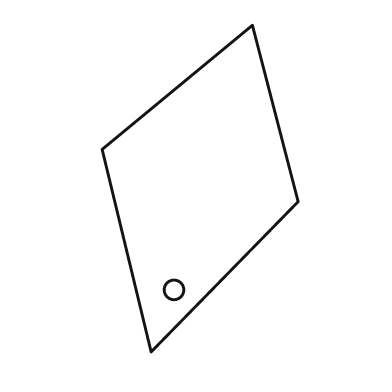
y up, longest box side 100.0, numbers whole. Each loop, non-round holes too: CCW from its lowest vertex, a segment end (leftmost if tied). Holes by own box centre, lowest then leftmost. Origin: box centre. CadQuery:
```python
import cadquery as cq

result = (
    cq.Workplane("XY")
    .moveTo(-15.0, -50.0)
    .lineTo(30.0, -4.0)
    .lineTo(16.0, 50.0)
    .lineTo(-30.0, 12.0)
    .close()
    .moveTo(-8.0, -31.0)
    .circle(3.0)
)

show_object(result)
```